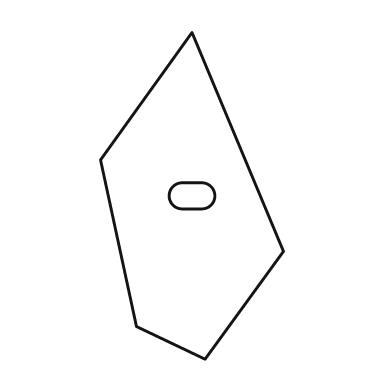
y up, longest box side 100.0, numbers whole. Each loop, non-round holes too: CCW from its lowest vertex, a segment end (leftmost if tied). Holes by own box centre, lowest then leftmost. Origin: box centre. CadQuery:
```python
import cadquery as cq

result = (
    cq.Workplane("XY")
    .moveTo(4.0, -50.0)
    .lineTo(28.0, -17.0)
    .lineTo(0.0, 50.0)
    .lineTo(-28.0, 11.0)
    .lineTo(-17.0, -40.0)
    .close()
    .moveTo(-3.0, -4.0)
    .lineTo(3.0, -4.0)
    .threePointArc((7.0, 0.0), (3.0, 4.0))
    .lineTo(-3.0, 4.0)
    .threePointArc((-7.0, 0.0), (-3.0, -4.0))
    .close()
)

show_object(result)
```